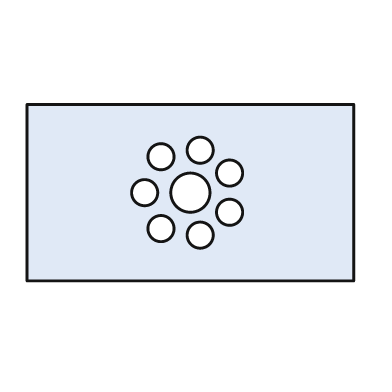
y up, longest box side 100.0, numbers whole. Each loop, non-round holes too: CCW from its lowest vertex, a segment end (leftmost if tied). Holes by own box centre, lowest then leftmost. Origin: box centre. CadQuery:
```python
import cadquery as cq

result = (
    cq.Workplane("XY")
    .moveTo(-50.0, -27.0)
    .lineTo(50.0, -27.0)
    .lineTo(50.0, 27.0)
    .lineTo(-50.0, 27.0)
    .close()
    .moveTo(3.0, -13.0)
    .circle(4.0)
    .moveTo(-9.0, -11.0)
    .circle(4.0)
    .moveTo(12.0, -6.0)
    .circle(4.0)
    .moveTo(-14.0, 0.0)
    .circle(4.0)
    .moveTo(0.0, 0.0)
    .circle(6.0)
    .moveTo(12.0, 6.0)
    .circle(4.0)
    .moveTo(-9.0, 11.0)
    .circle(4.0)
    .moveTo(3.0, 13.0)
    .circle(4.0)
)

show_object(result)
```